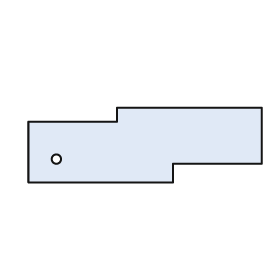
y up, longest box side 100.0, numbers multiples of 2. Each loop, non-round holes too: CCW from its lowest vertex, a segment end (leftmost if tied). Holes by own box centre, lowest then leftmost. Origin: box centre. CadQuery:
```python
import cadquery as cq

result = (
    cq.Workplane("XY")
    .moveTo(-50.0, -16.0)
    .lineTo(12.0, -16.0)
    .lineTo(12.0, -8.0)
    .lineTo(50.0, -8.0)
    .lineTo(50.0, 16.0)
    .lineTo(-12.0, 16.0)
    .lineTo(-12.0, 10.0)
    .lineTo(-50.0, 10.0)
    .close()
    .moveTo(-38.0, -6.0)
    .circle(2.0)
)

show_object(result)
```